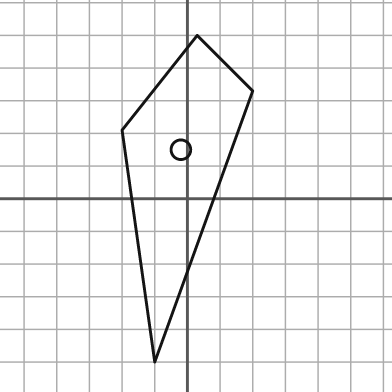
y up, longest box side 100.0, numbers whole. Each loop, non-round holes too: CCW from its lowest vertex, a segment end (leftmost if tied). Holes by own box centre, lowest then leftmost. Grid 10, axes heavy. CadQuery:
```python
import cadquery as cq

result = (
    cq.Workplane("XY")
    .moveTo(-10.0, -50.0)
    .lineTo(20.0, 33.0)
    .lineTo(3.0, 50.0)
    .lineTo(-20.0, 21.0)
    .close()
    .moveTo(-2.0, 15.0)
    .circle(3.0)
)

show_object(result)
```